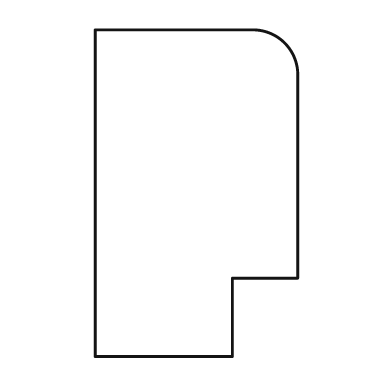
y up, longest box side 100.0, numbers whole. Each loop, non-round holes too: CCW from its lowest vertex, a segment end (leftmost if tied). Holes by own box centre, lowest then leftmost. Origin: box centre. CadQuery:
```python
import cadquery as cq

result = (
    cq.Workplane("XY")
    .moveTo(-31.0, -50.0)
    .lineTo(11.0, -50.0)
    .lineTo(11.0, -26.0)
    .lineTo(31.0, -26.0)
    .lineTo(31.0, 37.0)
    .threePointArc((27.0, 46.0), (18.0, 50.0))
    .lineTo(-31.0, 50.0)
    .close()
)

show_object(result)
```